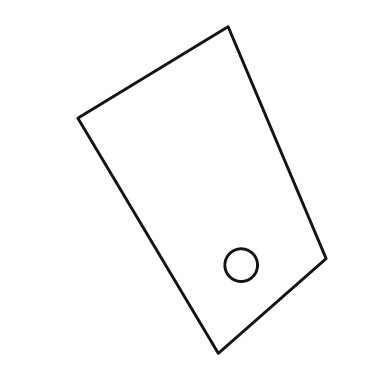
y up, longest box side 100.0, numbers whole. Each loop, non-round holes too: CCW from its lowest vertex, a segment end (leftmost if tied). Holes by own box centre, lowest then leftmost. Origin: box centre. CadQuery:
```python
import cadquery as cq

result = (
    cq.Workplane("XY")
    .moveTo(5.0, -50.0)
    .lineTo(38.0, -21.0)
    .lineTo(8.0, 50.0)
    .lineTo(-38.0, 22.0)
    .close()
    .moveTo(12.0, -23.0)
    .circle(5.0)
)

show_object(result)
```